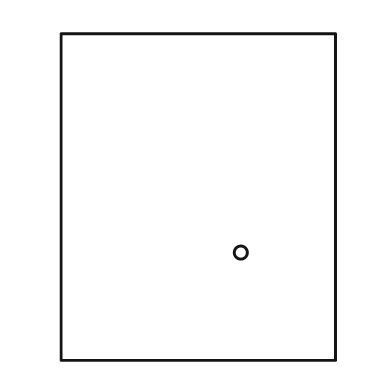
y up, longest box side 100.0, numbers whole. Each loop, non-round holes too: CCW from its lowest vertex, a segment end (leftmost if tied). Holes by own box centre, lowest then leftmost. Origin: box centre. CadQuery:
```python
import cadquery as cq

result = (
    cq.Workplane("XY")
    .moveTo(-42.0, -50.0)
    .lineTo(42.0, -50.0)
    .lineTo(42.0, 50.0)
    .lineTo(-42.0, 50.0)
    .close()
    .moveTo(13.0, -17.0)
    .circle(2.0)
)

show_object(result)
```